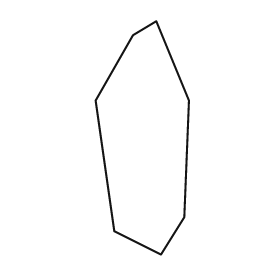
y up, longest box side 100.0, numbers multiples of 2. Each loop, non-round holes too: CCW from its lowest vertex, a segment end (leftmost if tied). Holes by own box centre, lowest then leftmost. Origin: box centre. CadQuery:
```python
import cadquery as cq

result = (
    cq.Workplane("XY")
    .moveTo(8.0, -50.0)
    .lineTo(18.0, -34.0)
    .lineTo(20.0, 16.0)
    .lineTo(6.0, 50.0)
    .lineTo(-4.0, 44.0)
    .lineTo(-20.0, 16.0)
    .lineTo(-12.0, -40.0)
    .close()
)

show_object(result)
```